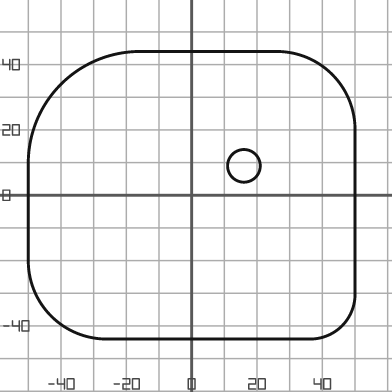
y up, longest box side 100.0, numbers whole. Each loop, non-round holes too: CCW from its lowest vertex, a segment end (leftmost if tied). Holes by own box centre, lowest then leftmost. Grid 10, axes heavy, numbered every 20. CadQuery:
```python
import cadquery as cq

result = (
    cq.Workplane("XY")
    .moveTo(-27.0, -44.0)
    .lineTo(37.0, -44.0)
    .threePointArc((46.0, -40.0), (50.0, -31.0))
    .lineTo(50.0, 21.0)
    .threePointArc((43.0, 37.0), (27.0, 44.0))
    .lineTo(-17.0, 44.0)
    .threePointArc((-40.0, 34.0), (-50.0, 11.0))
    .lineTo(-50.0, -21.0)
    .threePointArc((-43.0, -37.0), (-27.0, -44.0))
    .close()
    .moveTo(16.0, 9.0)
    .circle(5.0)
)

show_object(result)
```